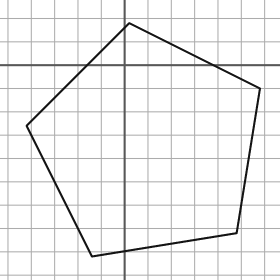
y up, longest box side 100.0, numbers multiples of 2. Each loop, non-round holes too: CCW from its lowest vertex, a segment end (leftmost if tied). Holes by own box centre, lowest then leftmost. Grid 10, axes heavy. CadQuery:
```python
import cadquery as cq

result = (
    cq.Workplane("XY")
    .moveTo(-14.0, -82.0)
    .lineTo(48.0, -72.0)
    .lineTo(58.0, -10.0)
    .lineTo(2.0, 18.0)
    .lineTo(-42.0, -26.0)
    .close()
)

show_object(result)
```